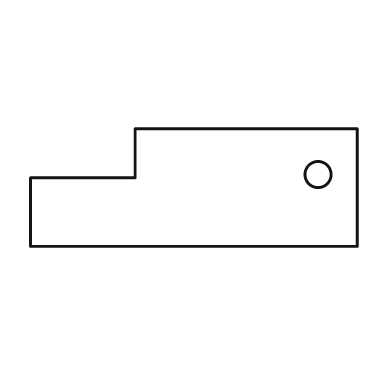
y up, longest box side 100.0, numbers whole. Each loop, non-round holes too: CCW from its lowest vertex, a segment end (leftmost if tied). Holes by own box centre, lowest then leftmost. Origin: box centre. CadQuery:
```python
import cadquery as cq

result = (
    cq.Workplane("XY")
    .moveTo(-50.0, -18.0)
    .lineTo(50.0, -18.0)
    .lineTo(50.0, 18.0)
    .lineTo(-18.0, 18.0)
    .lineTo(-18.0, 3.0)
    .lineTo(-50.0, 3.0)
    .close()
    .moveTo(38.0, 4.0)
    .circle(4.0)
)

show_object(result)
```